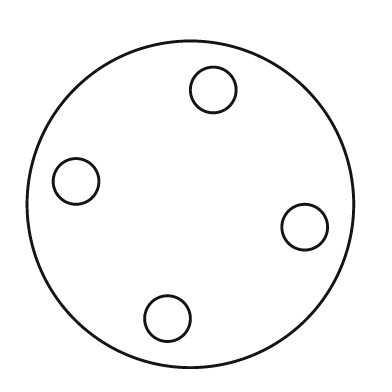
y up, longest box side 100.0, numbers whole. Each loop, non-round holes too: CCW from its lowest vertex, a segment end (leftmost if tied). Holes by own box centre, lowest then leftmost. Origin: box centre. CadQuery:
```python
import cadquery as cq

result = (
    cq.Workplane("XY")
    .moveTo(0.0, 0.0)
    .circle(50.0)
    .moveTo(-7.0, -35.0)
    .circle(7.0)
    .moveTo(35.0, -7.0)
    .circle(7.0)
    .moveTo(-35.0, 7.0)
    .circle(7.0)
    .moveTo(7.0, 35.0)
    .circle(7.0)
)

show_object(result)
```